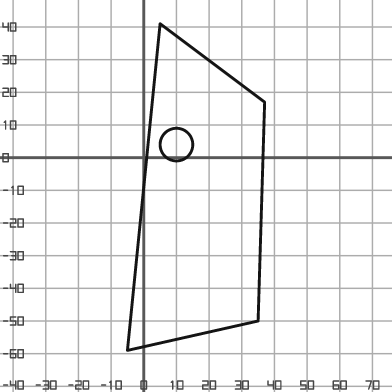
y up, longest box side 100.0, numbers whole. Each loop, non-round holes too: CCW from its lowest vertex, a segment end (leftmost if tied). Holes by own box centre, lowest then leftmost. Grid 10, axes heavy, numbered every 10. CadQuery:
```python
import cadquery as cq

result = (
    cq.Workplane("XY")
    .moveTo(-5.0, -59.0)
    .lineTo(35.0, -50.0)
    .lineTo(37.0, 17.0)
    .lineTo(5.0, 41.0)
    .close()
    .moveTo(10.0, 4.0)
    .circle(5.0)
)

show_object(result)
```